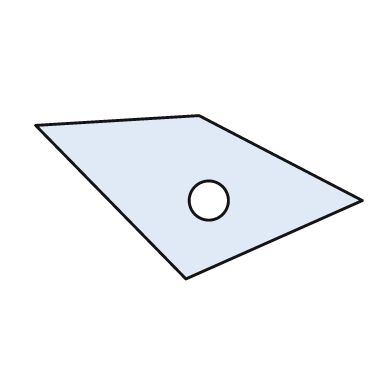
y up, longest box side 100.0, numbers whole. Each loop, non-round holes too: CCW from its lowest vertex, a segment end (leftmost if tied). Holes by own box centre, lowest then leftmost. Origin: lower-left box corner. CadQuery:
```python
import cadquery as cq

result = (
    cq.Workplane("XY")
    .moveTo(46.0, 0.0)
    .lineTo(100.0, 24.0)
    .lineTo(50.0, 50.0)
    .lineTo(0.0, 47.0)
    .close()
    .moveTo(53.0, 24.0)
    .circle(6.0)
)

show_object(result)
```